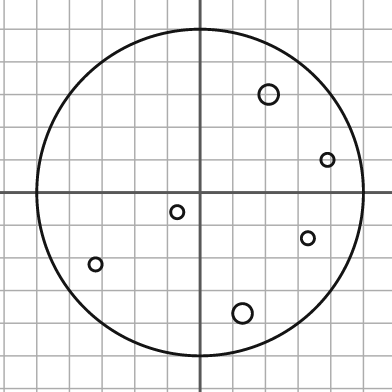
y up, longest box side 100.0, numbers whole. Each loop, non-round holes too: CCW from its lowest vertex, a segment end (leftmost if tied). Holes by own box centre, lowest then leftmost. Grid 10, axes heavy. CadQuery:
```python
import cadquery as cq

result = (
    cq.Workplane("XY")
    .moveTo(0.0, 0.0)
    .circle(50.0)
    .moveTo(13.0, -37.0)
    .circle(3.0)
    .moveTo(-32.0, -22.0)
    .circle(2.0)
    .moveTo(33.0, -14.0)
    .circle(2.0)
    .moveTo(-7.0, -6.0)
    .circle(2.0)
    .moveTo(39.0, 10.0)
    .circle(2.0)
    .moveTo(21.0, 30.0)
    .circle(3.0)
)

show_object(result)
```